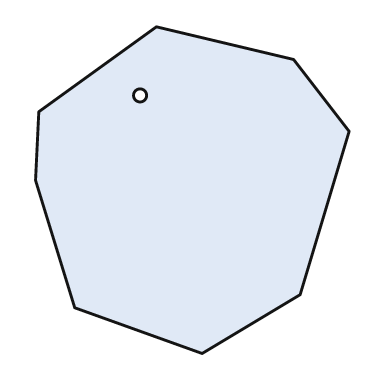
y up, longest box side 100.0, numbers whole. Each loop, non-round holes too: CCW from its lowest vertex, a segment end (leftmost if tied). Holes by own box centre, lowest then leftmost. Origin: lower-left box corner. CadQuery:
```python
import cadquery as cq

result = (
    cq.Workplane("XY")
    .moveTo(51.0, 0.0)
    .lineTo(81.0, 18.0)
    .lineTo(96.0, 68.0)
    .lineTo(79.0, 90.0)
    .lineTo(37.0, 100.0)
    .lineTo(1.0, 74.0)
    .lineTo(0.0, 53.0)
    .lineTo(12.0, 14.0)
    .close()
    .moveTo(32.0, 79.0)
    .circle(2.0)
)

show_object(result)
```